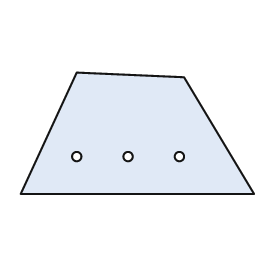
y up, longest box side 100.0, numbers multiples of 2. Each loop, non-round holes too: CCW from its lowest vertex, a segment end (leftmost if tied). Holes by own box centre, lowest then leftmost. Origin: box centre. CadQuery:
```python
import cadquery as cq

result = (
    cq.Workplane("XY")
    .moveTo(-50.0, -26.0)
    .lineTo(50.0, -26.0)
    .lineTo(20.0, 24.0)
    .lineTo(-26.0, 26.0)
    .close()
    .moveTo(-26.0, -10.0)
    .circle(2.0)
    .moveTo(-4.0, -10.0)
    .circle(2.0)
    .moveTo(18.0, -10.0)
    .circle(2.0)
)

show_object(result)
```